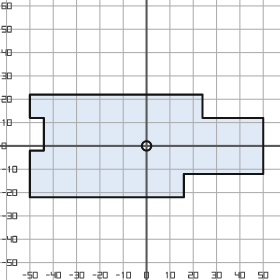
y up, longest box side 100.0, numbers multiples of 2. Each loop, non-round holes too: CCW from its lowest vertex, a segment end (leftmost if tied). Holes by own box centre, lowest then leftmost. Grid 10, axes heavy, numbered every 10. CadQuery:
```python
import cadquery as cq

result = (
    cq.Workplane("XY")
    .moveTo(-50.0, -22.0)
    .lineTo(16.0, -22.0)
    .lineTo(16.0, -12.0)
    .lineTo(50.0, -12.0)
    .lineTo(50.0, 12.0)
    .lineTo(24.0, 12.0)
    .lineTo(24.0, 22.0)
    .lineTo(-50.0, 22.0)
    .lineTo(-50.0, 12.0)
    .lineTo(-44.0, 12.0)
    .lineTo(-44.0, -2.0)
    .lineTo(-50.0, -2.0)
    .close()
    .moveTo(0.0, 0.0)
    .circle(2.0)
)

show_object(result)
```